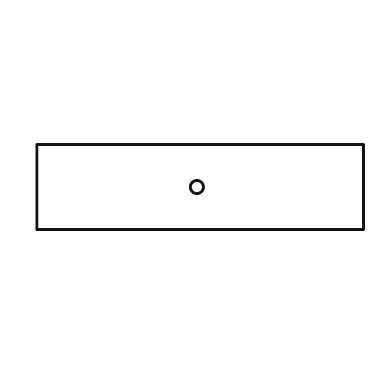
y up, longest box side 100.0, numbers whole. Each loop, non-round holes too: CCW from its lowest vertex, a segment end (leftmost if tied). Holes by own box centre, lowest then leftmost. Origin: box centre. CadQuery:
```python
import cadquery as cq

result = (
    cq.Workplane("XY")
    .moveTo(-50.0, -13.0)
    .lineTo(50.0, -13.0)
    .lineTo(50.0, 13.0)
    .lineTo(-50.0, 13.0)
    .close()
    .moveTo(-1.0, 0.0)
    .circle(2.0)
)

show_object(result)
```